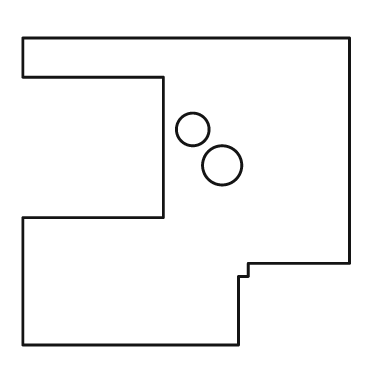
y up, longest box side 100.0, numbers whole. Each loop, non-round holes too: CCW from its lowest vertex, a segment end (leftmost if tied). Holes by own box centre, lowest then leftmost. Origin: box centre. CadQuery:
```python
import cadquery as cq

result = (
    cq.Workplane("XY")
    .moveTo(-50.0, -47.0)
    .lineTo(16.0, -47.0)
    .lineTo(16.0, -26.0)
    .lineTo(19.0, -26.0)
    .lineTo(19.0, -22.0)
    .lineTo(50.0, -22.0)
    .lineTo(50.0, 47.0)
    .lineTo(-50.0, 47.0)
    .lineTo(-50.0, 35.0)
    .lineTo(-7.0, 35.0)
    .lineTo(-7.0, -8.0)
    .lineTo(-50.0, -8.0)
    .close()
    .moveTo(11.0, 8.0)
    .circle(6.0)
    .moveTo(2.0, 19.0)
    .circle(5.0)
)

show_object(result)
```